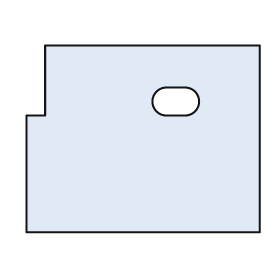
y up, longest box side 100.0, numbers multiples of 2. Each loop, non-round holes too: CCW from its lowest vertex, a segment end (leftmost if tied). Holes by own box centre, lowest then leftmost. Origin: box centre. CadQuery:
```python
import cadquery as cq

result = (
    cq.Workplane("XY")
    .moveTo(-50.0, -40.0)
    .lineTo(50.0, -40.0)
    .lineTo(50.0, 40.0)
    .lineTo(-42.0, 40.0)
    .lineTo(-42.0, 10.0)
    .lineTo(-50.0, 10.0)
    .close()
    .moveTo(10.0, 10.0)
    .lineTo(18.0, 10.0)
    .threePointArc((24.0, 16.0), (18.0, 22.0))
    .lineTo(10.0, 22.0)
    .threePointArc((4.0, 16.0), (10.0, 10.0))
    .close()
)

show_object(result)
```